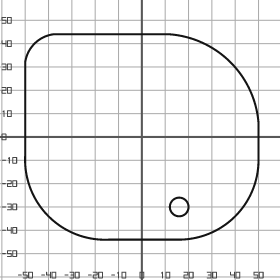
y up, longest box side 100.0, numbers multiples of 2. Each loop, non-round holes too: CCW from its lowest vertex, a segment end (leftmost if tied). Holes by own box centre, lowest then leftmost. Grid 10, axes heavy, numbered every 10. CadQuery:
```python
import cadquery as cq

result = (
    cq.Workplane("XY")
    .moveTo(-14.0, -44.0)
    .lineTo(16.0, -44.0)
    .threePointArc((40.0, -34.0), (50.0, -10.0))
    .lineTo(50.0, 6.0)
    .threePointArc((38.0, 32.0), (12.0, 44.0))
    .lineTo(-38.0, 44.0)
    .threePointArc((-46.0, 40.0), (-50.0, 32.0))
    .lineTo(-50.0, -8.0)
    .threePointArc((-40.0, -34.0), (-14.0, -44.0))
    .close()
    .moveTo(16.0, -30.0)
    .circle(4.0)
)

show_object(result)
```